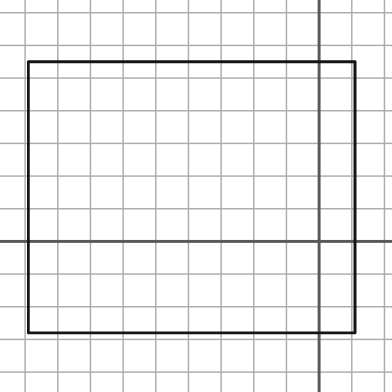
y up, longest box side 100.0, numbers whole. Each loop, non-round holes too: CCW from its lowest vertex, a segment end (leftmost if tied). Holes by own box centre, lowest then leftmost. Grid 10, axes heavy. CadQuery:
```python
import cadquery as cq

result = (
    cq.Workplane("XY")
    .moveTo(-89.0, -28.0)
    .lineTo(11.0, -28.0)
    .lineTo(11.0, 55.0)
    .lineTo(-89.0, 55.0)
    .close()
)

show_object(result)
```